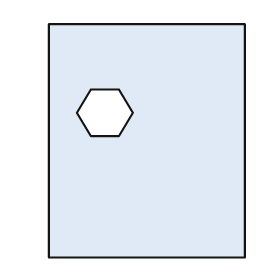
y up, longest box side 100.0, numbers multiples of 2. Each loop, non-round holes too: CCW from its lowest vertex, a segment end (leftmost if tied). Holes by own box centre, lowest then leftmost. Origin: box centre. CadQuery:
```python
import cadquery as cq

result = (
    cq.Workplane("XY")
    .moveTo(-42.0, -50.0)
    .lineTo(42.0, -50.0)
    .lineTo(42.0, 50.0)
    .lineTo(-42.0, 50.0)
    .close()
    .moveTo(-24.0, 2.0)
    .lineTo(-12.0, 2.0)
    .lineTo(-6.0, 12.0)
    .lineTo(-12.0, 22.0)
    .lineTo(-24.0, 22.0)
    .lineTo(-30.0, 12.0)
    .close()
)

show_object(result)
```